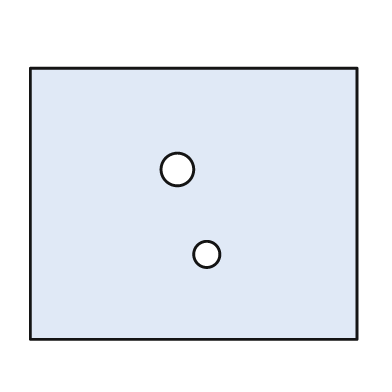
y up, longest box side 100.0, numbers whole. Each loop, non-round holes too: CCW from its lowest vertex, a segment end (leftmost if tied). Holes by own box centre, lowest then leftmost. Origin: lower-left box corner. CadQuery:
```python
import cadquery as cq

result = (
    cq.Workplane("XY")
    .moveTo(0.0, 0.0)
    .lineTo(100.0, 0.0)
    .lineTo(100.0, 83.0)
    .lineTo(0.0, 83.0)
    .close()
    .moveTo(54.0, 26.0)
    .circle(4.0)
    .moveTo(45.0, 52.0)
    .circle(5.0)
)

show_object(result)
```